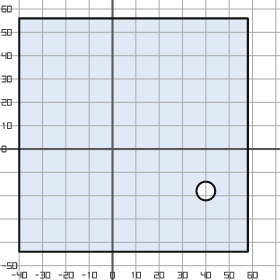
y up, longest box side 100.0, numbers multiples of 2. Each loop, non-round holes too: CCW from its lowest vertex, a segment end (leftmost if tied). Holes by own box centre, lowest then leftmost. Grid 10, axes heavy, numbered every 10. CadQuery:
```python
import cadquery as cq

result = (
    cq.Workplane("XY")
    .moveTo(-40.0, -44.0)
    .lineTo(58.0, -44.0)
    .lineTo(58.0, 56.0)
    .lineTo(-40.0, 56.0)
    .close()
    .moveTo(40.0, -18.0)
    .circle(4.0)
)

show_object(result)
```